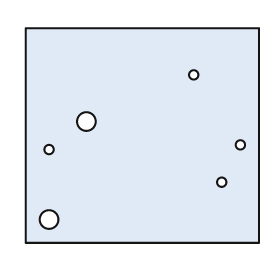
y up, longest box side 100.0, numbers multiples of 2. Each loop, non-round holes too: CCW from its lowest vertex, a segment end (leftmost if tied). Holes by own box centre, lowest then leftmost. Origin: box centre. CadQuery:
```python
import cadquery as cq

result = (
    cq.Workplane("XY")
    .moveTo(-50.0, -46.0)
    .lineTo(50.0, -46.0)
    .lineTo(50.0, 46.0)
    .lineTo(-50.0, 46.0)
    .close()
    .moveTo(-40.0, -36.0)
    .circle(4.0)
    .moveTo(34.0, -20.0)
    .circle(2.0)
    .moveTo(-40.0, -6.0)
    .circle(2.0)
    .moveTo(42.0, -4.0)
    .circle(2.0)
    .moveTo(-24.0, 6.0)
    .circle(4.0)
    .moveTo(22.0, 26.0)
    .circle(2.0)
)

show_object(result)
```